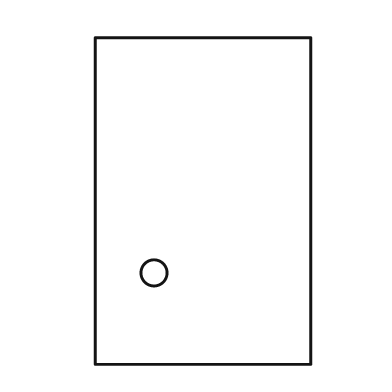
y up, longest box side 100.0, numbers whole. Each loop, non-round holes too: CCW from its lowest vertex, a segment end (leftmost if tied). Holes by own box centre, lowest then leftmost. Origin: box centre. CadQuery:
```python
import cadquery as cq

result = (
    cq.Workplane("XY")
    .moveTo(-33.0, -50.0)
    .lineTo(33.0, -50.0)
    .lineTo(33.0, 50.0)
    .lineTo(-33.0, 50.0)
    .close()
    .moveTo(-15.0, -22.0)
    .circle(4.0)
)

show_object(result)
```